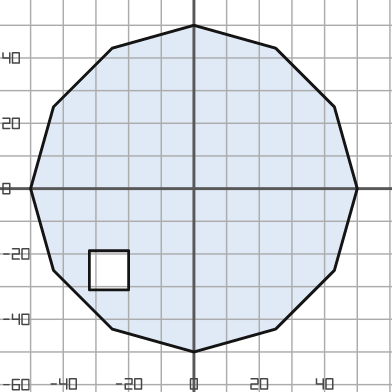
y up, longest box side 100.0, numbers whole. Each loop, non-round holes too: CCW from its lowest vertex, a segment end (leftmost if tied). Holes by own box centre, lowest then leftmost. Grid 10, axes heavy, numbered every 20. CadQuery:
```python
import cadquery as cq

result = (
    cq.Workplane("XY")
    .moveTo(0.0, -50.0)
    .lineTo(25.0, -43.0)
    .lineTo(43.0, -25.0)
    .lineTo(50.0, 0.0)
    .lineTo(43.0, 25.0)
    .lineTo(25.0, 43.0)
    .lineTo(0.0, 50.0)
    .lineTo(-25.0, 43.0)
    .lineTo(-43.0, 25.0)
    .lineTo(-50.0, 0.0)
    .lineTo(-43.0, -25.0)
    .lineTo(-25.0, -43.0)
    .close()
    .moveTo(-32.0, -31.0)
    .lineTo(-20.0, -31.0)
    .lineTo(-20.0, -19.0)
    .lineTo(-32.0, -19.0)
    .close()
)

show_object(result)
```